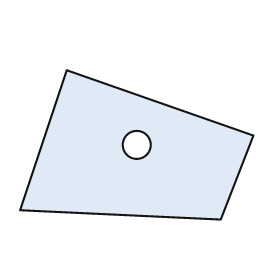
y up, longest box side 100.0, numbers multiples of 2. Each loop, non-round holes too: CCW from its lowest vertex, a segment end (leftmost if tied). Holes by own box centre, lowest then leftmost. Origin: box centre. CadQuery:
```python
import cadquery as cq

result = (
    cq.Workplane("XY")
    .moveTo(36.0, -32.0)
    .lineTo(50.0, 4.0)
    .lineTo(-30.0, 32.0)
    .lineTo(-50.0, -28.0)
    .close()
    .moveTo(0.0, 0.0)
    .circle(6.0)
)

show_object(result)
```